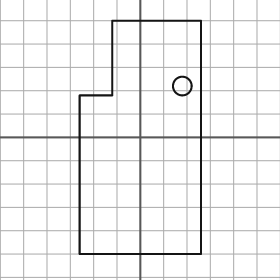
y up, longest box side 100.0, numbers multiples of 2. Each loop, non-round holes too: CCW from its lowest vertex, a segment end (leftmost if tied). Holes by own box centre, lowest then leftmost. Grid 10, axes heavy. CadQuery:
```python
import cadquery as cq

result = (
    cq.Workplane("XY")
    .moveTo(-26.0, -50.0)
    .lineTo(26.0, -50.0)
    .lineTo(26.0, 50.0)
    .lineTo(-12.0, 50.0)
    .lineTo(-12.0, 18.0)
    .lineTo(-26.0, 18.0)
    .close()
    .moveTo(18.0, 22.0)
    .circle(4.0)
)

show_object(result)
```